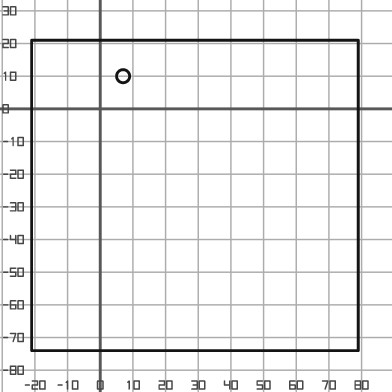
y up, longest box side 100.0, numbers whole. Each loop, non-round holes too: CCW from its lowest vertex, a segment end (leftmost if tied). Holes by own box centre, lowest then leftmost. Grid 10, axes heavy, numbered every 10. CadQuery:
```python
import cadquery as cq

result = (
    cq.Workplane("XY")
    .moveTo(-21.0, -74.0)
    .lineTo(79.0, -74.0)
    .lineTo(79.0, 21.0)
    .lineTo(-21.0, 21.0)
    .close()
    .moveTo(7.0, 10.0)
    .circle(2.0)
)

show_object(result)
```